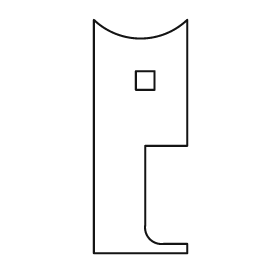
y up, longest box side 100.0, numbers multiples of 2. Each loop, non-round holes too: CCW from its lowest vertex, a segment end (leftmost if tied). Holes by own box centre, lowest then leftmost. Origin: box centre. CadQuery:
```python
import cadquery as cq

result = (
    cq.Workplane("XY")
    .moveTo(-20.0, -50.0)
    .lineTo(20.0, -50.0)
    .lineTo(20.0, -46.0)
    .lineTo(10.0, -46.0)
    .threePointArc((4.0, -44.0), (2.0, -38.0))
    .lineTo(2.0, -4.0)
    .lineTo(20.0, -4.0)
    .lineTo(20.0, 50.0)
    .threePointArc((0.0, 42.0), (-20.0, 50.0))
    .close()
    .moveTo(-2.0, 20.0)
    .lineTo(6.0, 20.0)
    .lineTo(6.0, 28.0)
    .lineTo(-2.0, 28.0)
    .close()
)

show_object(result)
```